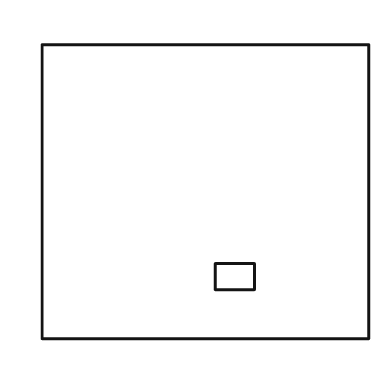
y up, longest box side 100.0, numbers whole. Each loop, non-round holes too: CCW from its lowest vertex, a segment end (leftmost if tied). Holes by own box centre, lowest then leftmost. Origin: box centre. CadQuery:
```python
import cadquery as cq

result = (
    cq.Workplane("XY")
    .moveTo(-50.0, -45.0)
    .lineTo(50.0, -45.0)
    .lineTo(50.0, 45.0)
    .lineTo(-50.0, 45.0)
    .close()
    .moveTo(3.0, -30.0)
    .lineTo(15.0, -30.0)
    .lineTo(15.0, -22.0)
    .lineTo(3.0, -22.0)
    .close()
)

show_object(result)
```